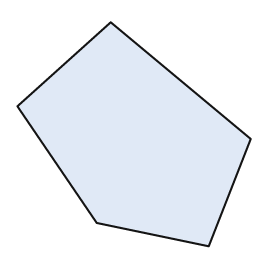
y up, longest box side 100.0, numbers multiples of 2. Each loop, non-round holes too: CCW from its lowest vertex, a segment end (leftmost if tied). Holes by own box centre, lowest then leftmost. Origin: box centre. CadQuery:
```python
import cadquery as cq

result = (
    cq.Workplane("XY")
    .moveTo(32.0, -48.0)
    .lineTo(50.0, -2.0)
    .lineTo(-10.0, 48.0)
    .lineTo(-50.0, 12.0)
    .lineTo(-16.0, -38.0)
    .close()
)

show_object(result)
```